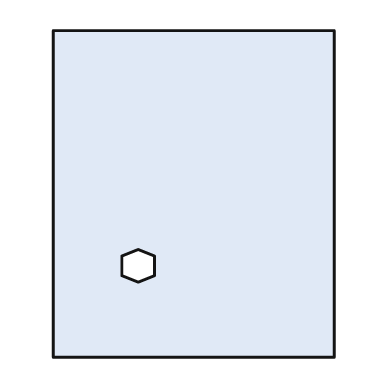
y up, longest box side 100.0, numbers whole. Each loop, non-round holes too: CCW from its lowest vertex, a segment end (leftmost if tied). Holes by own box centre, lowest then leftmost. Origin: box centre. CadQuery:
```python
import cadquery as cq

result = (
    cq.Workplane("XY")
    .moveTo(-43.0, -50.0)
    .lineTo(43.0, -50.0)
    .lineTo(43.0, 50.0)
    .lineTo(-43.0, 50.0)
    .close()
    .moveTo(-17.0, -27.0)
    .lineTo(-12.0, -25.0)
    .lineTo(-12.0, -19.0)
    .lineTo(-17.0, -17.0)
    .lineTo(-22.0, -19.0)
    .lineTo(-22.0, -25.0)
    .close()
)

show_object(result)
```